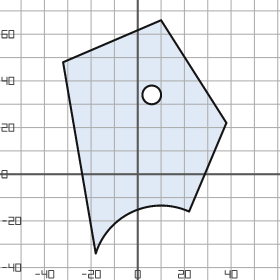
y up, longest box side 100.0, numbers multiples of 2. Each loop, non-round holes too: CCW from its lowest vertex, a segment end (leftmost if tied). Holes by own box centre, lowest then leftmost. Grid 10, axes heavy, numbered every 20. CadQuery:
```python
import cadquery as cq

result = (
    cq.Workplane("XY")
    .moveTo(-18.0, -34.0)
    .threePointArc((-2.0, -16.0), (22.0, -16.0))
    .lineTo(38.0, 22.0)
    .lineTo(10.0, 66.0)
    .lineTo(-32.0, 48.0)
    .close()
    .moveTo(6.0, 34.0)
    .circle(4.0)
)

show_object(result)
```